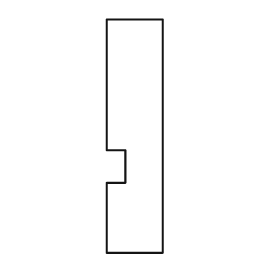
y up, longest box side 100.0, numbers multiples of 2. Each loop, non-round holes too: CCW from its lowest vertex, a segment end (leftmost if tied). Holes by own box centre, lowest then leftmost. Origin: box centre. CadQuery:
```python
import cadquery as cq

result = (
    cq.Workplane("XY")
    .moveTo(-12.0, -50.0)
    .lineTo(12.0, -50.0)
    .lineTo(12.0, 50.0)
    .lineTo(-12.0, 50.0)
    .lineTo(-12.0, -6.0)
    .lineTo(-4.0, -6.0)
    .lineTo(-4.0, -20.0)
    .lineTo(-12.0, -20.0)
    .close()
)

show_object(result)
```